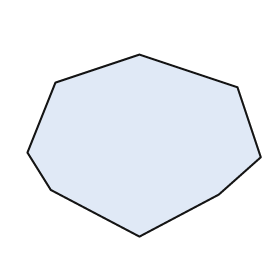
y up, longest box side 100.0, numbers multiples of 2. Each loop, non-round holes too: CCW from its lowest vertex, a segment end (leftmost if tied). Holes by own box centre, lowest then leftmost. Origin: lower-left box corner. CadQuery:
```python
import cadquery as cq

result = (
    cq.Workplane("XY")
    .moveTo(48.0, 0.0)
    .lineTo(82.0, 18.0)
    .lineTo(100.0, 34.0)
    .lineTo(90.0, 64.0)
    .lineTo(48.0, 78.0)
    .lineTo(12.0, 66.0)
    .lineTo(0.0, 36.0)
    .lineTo(10.0, 20.0)
    .close()
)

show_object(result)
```